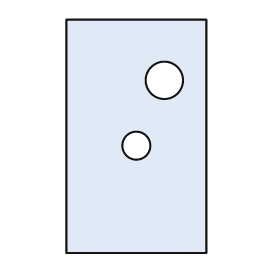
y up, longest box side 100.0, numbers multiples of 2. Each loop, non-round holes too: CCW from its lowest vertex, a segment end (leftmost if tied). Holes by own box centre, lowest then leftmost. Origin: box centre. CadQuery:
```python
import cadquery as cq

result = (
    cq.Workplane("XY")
    .moveTo(-30.0, -50.0)
    .lineTo(30.0, -50.0)
    .lineTo(30.0, 50.0)
    .lineTo(-30.0, 50.0)
    .close()
    .moveTo(0.0, -4.0)
    .circle(6.0)
    .moveTo(12.0, 24.0)
    .circle(8.0)
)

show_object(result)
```